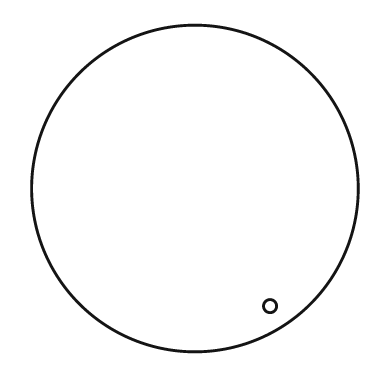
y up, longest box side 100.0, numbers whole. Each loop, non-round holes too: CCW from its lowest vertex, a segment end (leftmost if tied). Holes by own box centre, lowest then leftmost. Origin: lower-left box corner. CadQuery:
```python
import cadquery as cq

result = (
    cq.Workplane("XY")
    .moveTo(50.0, 50.0)
    .circle(50.0)
    .moveTo(73.0, 14.0)
    .circle(2.0)
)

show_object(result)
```